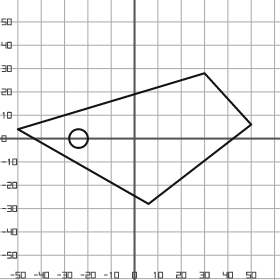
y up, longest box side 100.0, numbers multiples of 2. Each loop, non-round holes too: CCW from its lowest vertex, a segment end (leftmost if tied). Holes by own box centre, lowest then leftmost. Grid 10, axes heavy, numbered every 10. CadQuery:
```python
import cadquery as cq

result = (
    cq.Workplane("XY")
    .moveTo(6.0, -28.0)
    .lineTo(50.0, 6.0)
    .lineTo(30.0, 28.0)
    .lineTo(-50.0, 4.0)
    .close()
    .moveTo(-24.0, 0.0)
    .circle(4.0)
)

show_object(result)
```